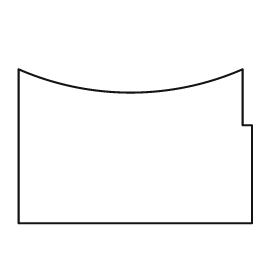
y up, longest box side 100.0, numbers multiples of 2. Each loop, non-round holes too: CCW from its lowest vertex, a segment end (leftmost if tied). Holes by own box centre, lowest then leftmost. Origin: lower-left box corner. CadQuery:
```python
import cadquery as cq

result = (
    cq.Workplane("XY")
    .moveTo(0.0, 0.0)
    .lineTo(100.0, 0.0)
    .lineTo(100.0, 42.0)
    .lineTo(96.0, 42.0)
    .lineTo(96.0, 66.0)
    .threePointArc((48.0, 56.0), (0.0, 66.0))
    .close()
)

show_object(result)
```